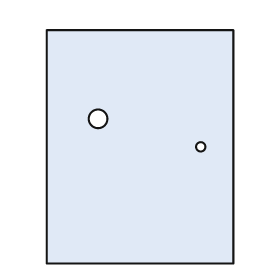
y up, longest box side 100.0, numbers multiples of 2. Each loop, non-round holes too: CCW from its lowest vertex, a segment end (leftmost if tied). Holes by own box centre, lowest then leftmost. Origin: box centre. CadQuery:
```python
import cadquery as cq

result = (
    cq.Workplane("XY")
    .moveTo(-40.0, -50.0)
    .lineTo(40.0, -50.0)
    .lineTo(40.0, 50.0)
    .lineTo(-40.0, 50.0)
    .close()
    .moveTo(26.0, 0.0)
    .circle(2.0)
    .moveTo(-18.0, 12.0)
    .circle(4.0)
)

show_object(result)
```